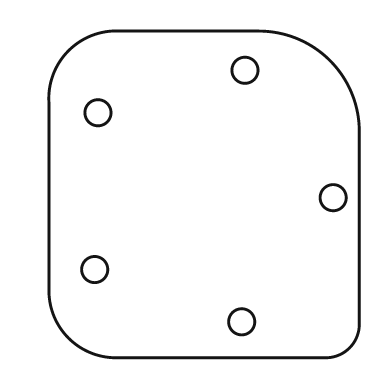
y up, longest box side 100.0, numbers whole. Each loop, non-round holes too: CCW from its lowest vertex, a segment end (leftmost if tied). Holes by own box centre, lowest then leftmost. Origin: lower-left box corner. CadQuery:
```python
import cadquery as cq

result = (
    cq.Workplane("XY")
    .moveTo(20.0, 0.0)
    .lineTo(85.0, 0.0)
    .threePointArc((92.0, 3.0), (95.0, 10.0))
    .lineTo(95.0, 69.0)
    .threePointArc((86.0, 91.0), (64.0, 100.0))
    .lineTo(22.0, 100.0)
    .threePointArc((6.0, 94.0), (0.0, 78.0))
    .lineTo(0.0, 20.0)
    .threePointArc((6.0, 6.0), (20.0, 0.0))
    .close()
    .moveTo(59.0, 11.0)
    .circle(4.0)
    .moveTo(14.0, 27.0)
    .circle(4.0)
    .moveTo(87.0, 49.0)
    .circle(4.0)
    .moveTo(15.0, 75.0)
    .circle(4.0)
    .moveTo(60.0, 88.0)
    .circle(4.0)
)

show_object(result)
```